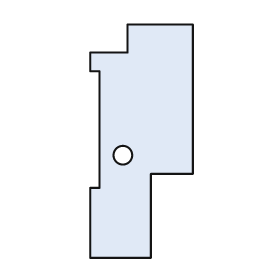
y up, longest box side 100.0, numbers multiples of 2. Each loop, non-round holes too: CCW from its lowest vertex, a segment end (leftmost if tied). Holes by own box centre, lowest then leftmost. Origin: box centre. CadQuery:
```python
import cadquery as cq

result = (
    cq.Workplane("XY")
    .moveTo(-22.0, -50.0)
    .lineTo(4.0, -50.0)
    .lineTo(4.0, -14.0)
    .lineTo(22.0, -14.0)
    .lineTo(22.0, 50.0)
    .lineTo(-6.0, 50.0)
    .lineTo(-6.0, 38.0)
    .lineTo(-22.0, 38.0)
    .lineTo(-22.0, 30.0)
    .lineTo(-18.0, 30.0)
    .lineTo(-18.0, -20.0)
    .lineTo(-22.0, -20.0)
    .close()
    .moveTo(-8.0, -6.0)
    .circle(4.0)
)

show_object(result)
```